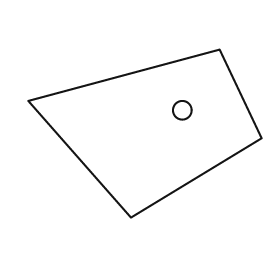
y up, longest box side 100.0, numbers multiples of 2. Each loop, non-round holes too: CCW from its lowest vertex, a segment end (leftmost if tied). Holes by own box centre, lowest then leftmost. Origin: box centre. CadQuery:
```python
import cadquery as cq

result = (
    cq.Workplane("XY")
    .moveTo(-6.0, -36.0)
    .lineTo(50.0, -2.0)
    .lineTo(32.0, 36.0)
    .lineTo(-50.0, 14.0)
    .close()
    .moveTo(16.0, 10.0)
    .circle(4.0)
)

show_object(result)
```